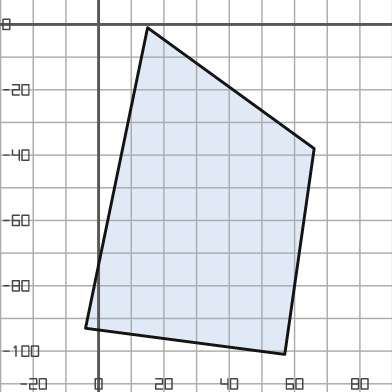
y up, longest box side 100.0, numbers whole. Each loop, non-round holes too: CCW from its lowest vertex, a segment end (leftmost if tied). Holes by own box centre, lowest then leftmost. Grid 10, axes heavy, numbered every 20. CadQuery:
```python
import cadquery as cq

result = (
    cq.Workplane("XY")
    .moveTo(57.0, -101.0)
    .lineTo(66.0, -38.0)
    .lineTo(15.0, -1.0)
    .lineTo(-4.0, -93.0)
    .close()
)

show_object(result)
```